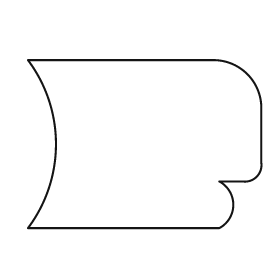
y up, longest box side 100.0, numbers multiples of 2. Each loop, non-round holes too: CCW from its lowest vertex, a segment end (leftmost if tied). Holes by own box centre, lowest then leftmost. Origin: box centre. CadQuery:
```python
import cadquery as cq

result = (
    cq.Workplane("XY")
    .moveTo(-50.0, -36.0)
    .lineTo(32.0, -36.0)
    .threePointArc((38.0, -26.0), (32.0, -16.0))
    .lineTo(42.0, -16.0)
    .threePointArc((48.0, -14.0), (50.0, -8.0))
    .lineTo(50.0, 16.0)
    .threePointArc((44.0, 30.0), (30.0, 36.0))
    .lineTo(-50.0, 36.0)
    .threePointArc((-38.0, 0.0), (-50.0, -36.0))
    .close()
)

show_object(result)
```